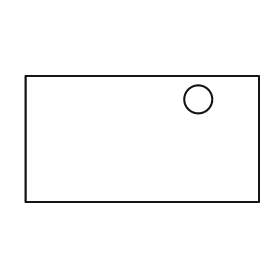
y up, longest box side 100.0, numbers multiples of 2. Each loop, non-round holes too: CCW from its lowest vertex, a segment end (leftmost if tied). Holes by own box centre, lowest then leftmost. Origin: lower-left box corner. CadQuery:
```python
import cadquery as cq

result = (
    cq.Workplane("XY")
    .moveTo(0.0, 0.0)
    .lineTo(100.0, 0.0)
    .lineTo(100.0, 54.0)
    .lineTo(0.0, 54.0)
    .close()
    .moveTo(74.0, 44.0)
    .circle(6.0)
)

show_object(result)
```